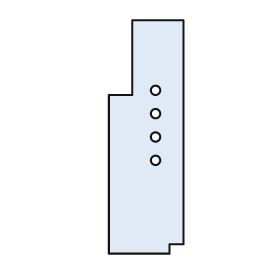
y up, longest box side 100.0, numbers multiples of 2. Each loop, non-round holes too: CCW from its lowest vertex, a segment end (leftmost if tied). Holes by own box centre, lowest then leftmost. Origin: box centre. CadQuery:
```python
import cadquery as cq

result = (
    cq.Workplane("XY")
    .moveTo(-16.0, -50.0)
    .lineTo(10.0, -50.0)
    .lineTo(10.0, -46.0)
    .lineTo(16.0, -46.0)
    .lineTo(16.0, 50.0)
    .lineTo(-6.0, 50.0)
    .lineTo(-6.0, 18.0)
    .lineTo(-16.0, 18.0)
    .close()
    .moveTo(4.0, -10.0)
    .circle(2.0)
    .moveTo(4.0, 0.0)
    .circle(2.0)
    .moveTo(4.0, 10.0)
    .circle(2.0)
    .moveTo(4.0, 20.0)
    .circle(2.0)
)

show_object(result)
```